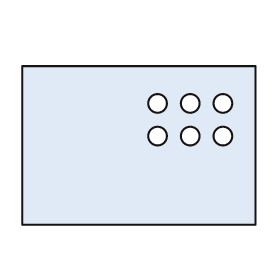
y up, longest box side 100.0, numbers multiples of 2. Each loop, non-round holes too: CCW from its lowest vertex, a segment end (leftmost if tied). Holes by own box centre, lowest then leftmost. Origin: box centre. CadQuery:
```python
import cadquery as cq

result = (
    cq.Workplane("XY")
    .moveTo(-50.0, -34.0)
    .lineTo(50.0, -34.0)
    .lineTo(50.0, 34.0)
    .lineTo(-50.0, 34.0)
    .close()
    .moveTo(8.0, 4.0)
    .circle(4.0)
    .moveTo(22.0, 4.0)
    .circle(4.0)
    .moveTo(36.0, 4.0)
    .circle(4.0)
    .moveTo(8.0, 18.0)
    .circle(4.0)
    .moveTo(22.0, 18.0)
    .circle(4.0)
    .moveTo(36.0, 18.0)
    .circle(4.0)
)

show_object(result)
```